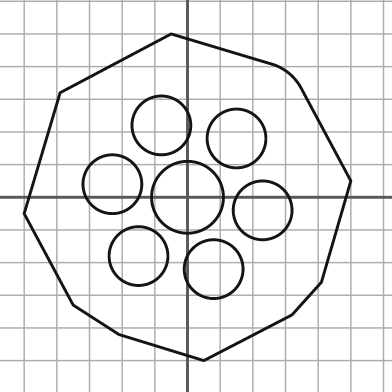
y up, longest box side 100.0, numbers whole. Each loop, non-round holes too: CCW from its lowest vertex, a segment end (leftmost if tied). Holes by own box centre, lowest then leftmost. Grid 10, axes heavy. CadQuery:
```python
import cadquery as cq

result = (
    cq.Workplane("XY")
    .moveTo(5.0, -50.0)
    .lineTo(32.0, -36.0)
    .lineTo(41.0, -26.0)
    .lineTo(50.0, 5.0)
    .lineTo(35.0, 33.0)
    .threePointArc((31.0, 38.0), (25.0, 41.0))
    .lineTo(-5.0, 50.0)
    .lineTo(-39.0, 32.0)
    .lineTo(-50.0, -5.0)
    .lineTo(-35.0, -33.0)
    .lineTo(-21.0, -42.0)
    .close()
    .moveTo(8.0, -22.0)
    .circle(9.0)
    .moveTo(-15.0, -18.0)
    .circle(9.0)
    .moveTo(23.0, -4.0)
    .circle(9.0)
    .moveTo(0.0, 0.0)
    .circle(11.0)
    .moveTo(-23.0, 4.0)
    .circle(9.0)
    .moveTo(15.0, 18.0)
    .circle(9.0)
    .moveTo(-8.0, 22.0)
    .circle(9.0)
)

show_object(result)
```